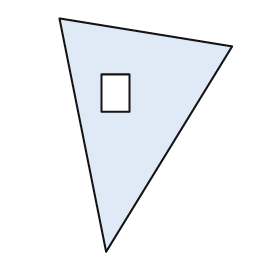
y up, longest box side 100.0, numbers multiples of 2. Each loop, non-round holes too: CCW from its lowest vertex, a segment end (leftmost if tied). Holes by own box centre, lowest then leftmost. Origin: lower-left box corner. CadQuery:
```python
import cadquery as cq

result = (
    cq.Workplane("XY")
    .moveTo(20.0, 0.0)
    .lineTo(74.0, 88.0)
    .lineTo(0.0, 100.0)
    .close()
    .moveTo(18.0, 60.0)
    .lineTo(30.0, 60.0)
    .lineTo(30.0, 76.0)
    .lineTo(18.0, 76.0)
    .close()
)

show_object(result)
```